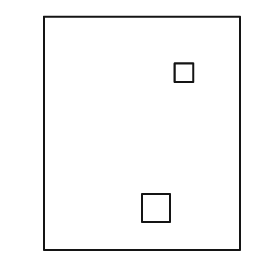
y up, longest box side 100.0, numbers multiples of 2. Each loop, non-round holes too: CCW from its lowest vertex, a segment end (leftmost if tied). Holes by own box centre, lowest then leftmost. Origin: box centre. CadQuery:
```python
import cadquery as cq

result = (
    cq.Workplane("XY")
    .moveTo(-42.0, -50.0)
    .lineTo(42.0, -50.0)
    .lineTo(42.0, 50.0)
    .lineTo(-42.0, 50.0)
    .close()
    .moveTo(0.0, -38.0)
    .lineTo(12.0, -38.0)
    .lineTo(12.0, -26.0)
    .lineTo(0.0, -26.0)
    .close()
    .moveTo(14.0, 22.0)
    .lineTo(22.0, 22.0)
    .lineTo(22.0, 30.0)
    .lineTo(14.0, 30.0)
    .close()
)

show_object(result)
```